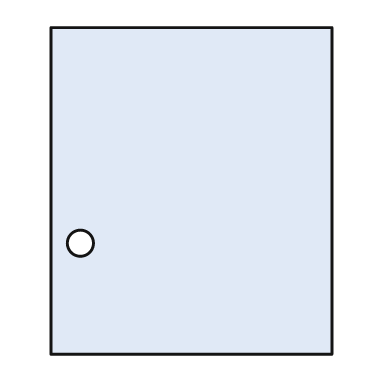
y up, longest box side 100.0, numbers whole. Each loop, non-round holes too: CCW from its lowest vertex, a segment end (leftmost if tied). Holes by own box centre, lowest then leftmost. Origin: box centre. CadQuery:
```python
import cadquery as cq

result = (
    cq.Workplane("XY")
    .moveTo(-43.0, -50.0)
    .lineTo(43.0, -50.0)
    .lineTo(43.0, 50.0)
    .lineTo(-43.0, 50.0)
    .close()
    .moveTo(-34.0, -16.0)
    .circle(4.0)
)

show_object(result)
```